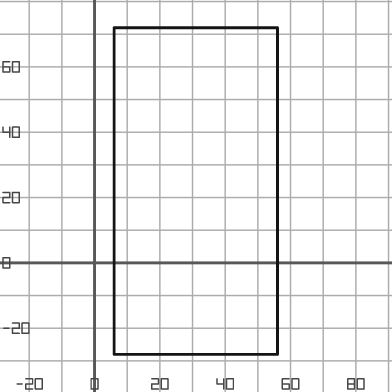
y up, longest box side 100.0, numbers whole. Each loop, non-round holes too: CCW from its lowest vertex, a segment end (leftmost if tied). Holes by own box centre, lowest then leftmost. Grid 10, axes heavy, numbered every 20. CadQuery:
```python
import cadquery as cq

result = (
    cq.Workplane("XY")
    .moveTo(6.0, -28.0)
    .lineTo(56.0, -28.0)
    .lineTo(56.0, 72.0)
    .lineTo(6.0, 72.0)
    .close()
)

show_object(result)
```